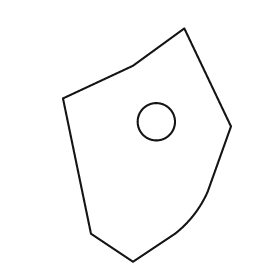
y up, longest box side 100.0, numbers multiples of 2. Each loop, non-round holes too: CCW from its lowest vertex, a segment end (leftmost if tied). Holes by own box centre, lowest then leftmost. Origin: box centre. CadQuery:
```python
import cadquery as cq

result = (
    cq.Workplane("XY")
    .moveTo(-6.0, -50.0)
    .lineTo(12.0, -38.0)
    .threePointArc((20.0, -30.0), (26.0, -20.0))
    .lineTo(36.0, 8.0)
    .lineTo(16.0, 50.0)
    .lineTo(-6.0, 34.0)
    .lineTo(-36.0, 20.0)
    .lineTo(-24.0, -38.0)
    .close()
    .moveTo(4.0, 10.0)
    .circle(8.0)
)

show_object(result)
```